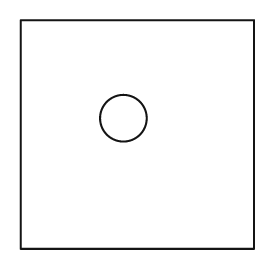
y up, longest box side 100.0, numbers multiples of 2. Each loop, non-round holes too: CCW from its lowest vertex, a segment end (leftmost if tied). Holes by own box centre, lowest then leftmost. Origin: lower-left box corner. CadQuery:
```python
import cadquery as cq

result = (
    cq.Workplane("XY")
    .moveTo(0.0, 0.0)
    .lineTo(100.0, 0.0)
    .lineTo(100.0, 98.0)
    .lineTo(0.0, 98.0)
    .close()
    .moveTo(44.0, 56.0)
    .circle(10.0)
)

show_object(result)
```